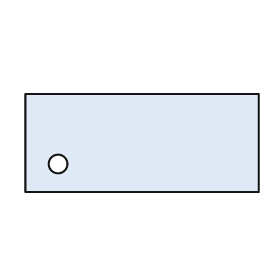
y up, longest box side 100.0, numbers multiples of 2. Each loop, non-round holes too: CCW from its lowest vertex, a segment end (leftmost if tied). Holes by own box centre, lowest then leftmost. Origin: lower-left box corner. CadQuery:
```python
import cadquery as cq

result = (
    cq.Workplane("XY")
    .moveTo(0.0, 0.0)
    .lineTo(100.0, 0.0)
    .lineTo(100.0, 42.0)
    .lineTo(0.0, 42.0)
    .close()
    .moveTo(14.0, 12.0)
    .circle(4.0)
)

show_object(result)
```